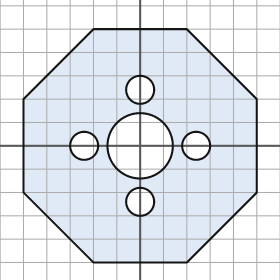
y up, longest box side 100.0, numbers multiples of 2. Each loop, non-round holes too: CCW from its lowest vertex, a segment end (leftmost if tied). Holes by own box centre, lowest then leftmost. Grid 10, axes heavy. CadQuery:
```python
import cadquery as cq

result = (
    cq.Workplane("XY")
    .moveTo(-20.0, -50.0)
    .lineTo(20.0, -50.0)
    .lineTo(50.0, -20.0)
    .lineTo(50.0, 20.0)
    .lineTo(20.0, 50.0)
    .lineTo(-20.0, 50.0)
    .lineTo(-50.0, 20.0)
    .lineTo(-50.0, -20.0)
    .close()
    .moveTo(0.0, -24.0)
    .circle(6.0)
    .moveTo(-24.0, 0.0)
    .circle(6.0)
    .moveTo(0.0, 0.0)
    .circle(14.0)
    .moveTo(24.0, 0.0)
    .circle(6.0)
    .moveTo(0.0, 24.0)
    .circle(6.0)
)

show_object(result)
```